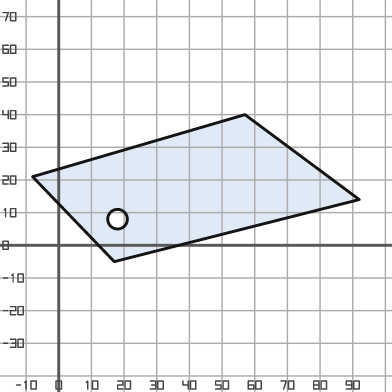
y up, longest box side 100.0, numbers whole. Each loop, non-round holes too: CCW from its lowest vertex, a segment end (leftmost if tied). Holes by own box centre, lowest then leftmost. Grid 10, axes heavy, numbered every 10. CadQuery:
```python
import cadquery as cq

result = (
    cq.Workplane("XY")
    .moveTo(17.0, -5.0)
    .lineTo(92.0, 14.0)
    .lineTo(57.0, 40.0)
    .lineTo(-8.0, 21.0)
    .close()
    .moveTo(18.0, 8.0)
    .circle(3.0)
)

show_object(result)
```